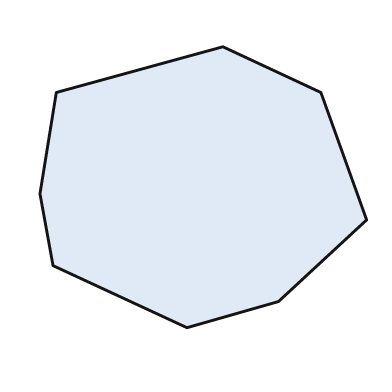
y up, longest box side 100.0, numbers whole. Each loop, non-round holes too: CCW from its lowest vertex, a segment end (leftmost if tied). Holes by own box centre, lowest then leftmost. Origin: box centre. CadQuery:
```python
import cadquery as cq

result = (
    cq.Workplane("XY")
    .moveTo(-5.0, -43.0)
    .lineTo(23.0, -35.0)
    .lineTo(50.0, -10.0)
    .lineTo(36.0, 29.0)
    .lineTo(6.0, 43.0)
    .lineTo(-45.0, 29.0)
    .lineTo(-50.0, -2.0)
    .lineTo(-46.0, -24.0)
    .close()
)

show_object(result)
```